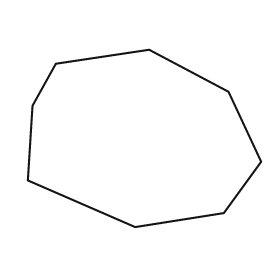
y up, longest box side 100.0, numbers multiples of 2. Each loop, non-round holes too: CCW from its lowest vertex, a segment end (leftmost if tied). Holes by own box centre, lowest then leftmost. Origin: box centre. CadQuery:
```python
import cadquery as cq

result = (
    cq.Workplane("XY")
    .moveTo(-4.0, -38.0)
    .lineTo(34.0, -32.0)
    .lineTo(50.0, -10.0)
    .lineTo(36.0, 20.0)
    .lineTo(2.0, 38.0)
    .lineTo(-38.0, 32.0)
    .lineTo(-48.0, 14.0)
    .lineTo(-50.0, -18.0)
    .close()
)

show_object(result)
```